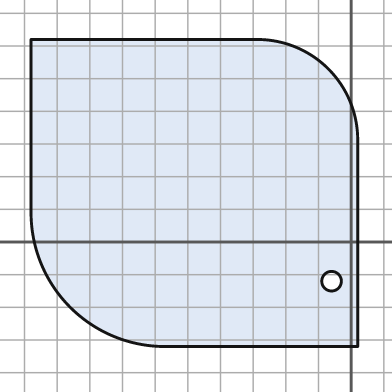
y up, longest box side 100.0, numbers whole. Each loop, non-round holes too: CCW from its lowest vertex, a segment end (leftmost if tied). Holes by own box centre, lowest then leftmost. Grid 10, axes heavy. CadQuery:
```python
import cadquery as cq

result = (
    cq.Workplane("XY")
    .moveTo(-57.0, -32.0)
    .lineTo(2.0, -32.0)
    .lineTo(2.0, 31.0)
    .threePointArc((-7.0, 53.0), (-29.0, 62.0))
    .lineTo(-98.0, 62.0)
    .lineTo(-98.0, 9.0)
    .threePointArc((-86.0, -20.0), (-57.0, -32.0))
    .close()
    .moveTo(-6.0, -12.0)
    .circle(3.0)
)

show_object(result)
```